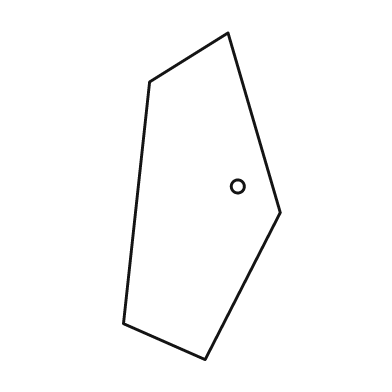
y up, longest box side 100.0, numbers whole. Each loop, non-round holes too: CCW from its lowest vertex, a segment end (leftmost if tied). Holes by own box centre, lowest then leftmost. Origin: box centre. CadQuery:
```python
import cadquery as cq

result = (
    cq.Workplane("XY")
    .moveTo(1.0, -50.0)
    .lineTo(24.0, -5.0)
    .lineTo(8.0, 50.0)
    .lineTo(-16.0, 35.0)
    .lineTo(-24.0, -39.0)
    .close()
    .moveTo(11.0, 3.0)
    .circle(2.0)
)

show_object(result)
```